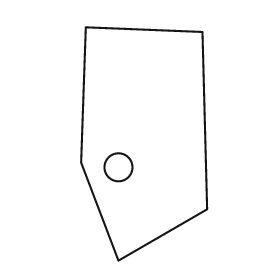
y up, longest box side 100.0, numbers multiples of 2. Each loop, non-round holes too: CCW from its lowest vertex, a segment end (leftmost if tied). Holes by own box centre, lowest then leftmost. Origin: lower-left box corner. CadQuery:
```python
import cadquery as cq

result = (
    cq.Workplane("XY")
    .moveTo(16.0, 0.0)
    .lineTo(54.0, 22.0)
    .lineTo(52.0, 98.0)
    .lineTo(2.0, 100.0)
    .lineTo(0.0, 42.0)
    .close()
    .moveTo(16.0, 40.0)
    .circle(6.0)
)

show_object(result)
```